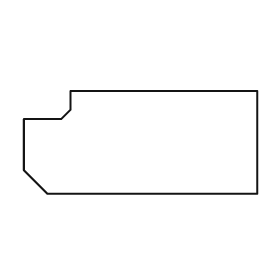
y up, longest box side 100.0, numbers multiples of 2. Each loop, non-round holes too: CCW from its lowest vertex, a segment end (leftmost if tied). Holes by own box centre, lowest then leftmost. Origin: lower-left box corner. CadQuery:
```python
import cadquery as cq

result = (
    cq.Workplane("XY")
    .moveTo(10.0, 0.0)
    .lineTo(100.0, 0.0)
    .lineTo(100.0, 44.0)
    .lineTo(20.0, 44.0)
    .lineTo(20.0, 36.0)
    .lineTo(16.0, 32.0)
    .lineTo(0.0, 32.0)
    .lineTo(0.0, 10.0)
    .close()
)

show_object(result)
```